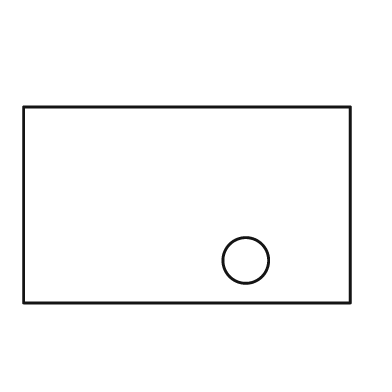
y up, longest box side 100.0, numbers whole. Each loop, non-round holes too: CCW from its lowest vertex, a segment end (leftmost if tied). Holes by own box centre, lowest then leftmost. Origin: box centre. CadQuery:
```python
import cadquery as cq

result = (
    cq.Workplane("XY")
    .moveTo(-50.0, -30.0)
    .lineTo(50.0, -30.0)
    .lineTo(50.0, 30.0)
    .lineTo(-50.0, 30.0)
    .close()
    .moveTo(18.0, -17.0)
    .circle(7.0)
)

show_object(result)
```